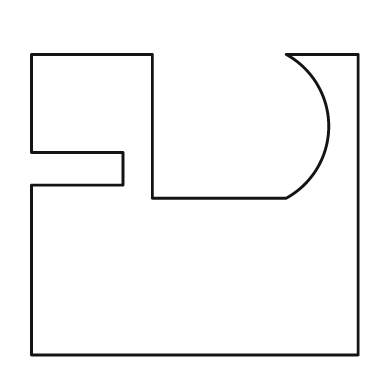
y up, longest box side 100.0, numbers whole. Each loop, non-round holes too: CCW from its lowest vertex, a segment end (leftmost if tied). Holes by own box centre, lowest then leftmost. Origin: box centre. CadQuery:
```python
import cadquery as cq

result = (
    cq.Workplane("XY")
    .moveTo(-50.0, -46.0)
    .lineTo(50.0, -46.0)
    .lineTo(50.0, 46.0)
    .lineTo(28.0, 46.0)
    .threePointArc((41.0, 24.0), (28.0, 2.0))
    .lineTo(-13.0, 2.0)
    .lineTo(-13.0, 46.0)
    .lineTo(-50.0, 46.0)
    .lineTo(-50.0, 16.0)
    .lineTo(-22.0, 16.0)
    .lineTo(-22.0, 6.0)
    .lineTo(-50.0, 6.0)
    .close()
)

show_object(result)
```